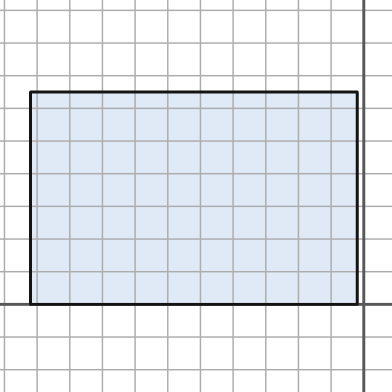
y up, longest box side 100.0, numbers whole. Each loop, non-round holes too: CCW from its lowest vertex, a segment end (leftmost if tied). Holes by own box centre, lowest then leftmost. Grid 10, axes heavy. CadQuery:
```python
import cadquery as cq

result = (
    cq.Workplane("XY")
    .moveTo(-102.0, 0.0)
    .lineTo(-2.0, 0.0)
    .lineTo(-2.0, 65.0)
    .lineTo(-102.0, 65.0)
    .close()
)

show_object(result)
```